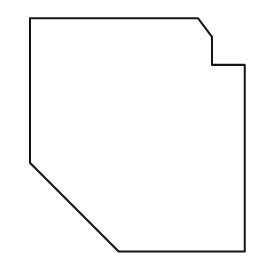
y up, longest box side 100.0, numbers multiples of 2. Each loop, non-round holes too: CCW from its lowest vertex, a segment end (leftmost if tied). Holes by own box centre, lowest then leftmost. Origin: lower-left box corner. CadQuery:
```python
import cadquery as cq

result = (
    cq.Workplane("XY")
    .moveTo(38.0, 0.0)
    .lineTo(92.0, 0.0)
    .lineTo(92.0, 80.0)
    .lineTo(78.0, 80.0)
    .lineTo(78.0, 92.0)
    .lineTo(72.0, 100.0)
    .lineTo(0.0, 100.0)
    .lineTo(0.0, 38.0)
    .close()
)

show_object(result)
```